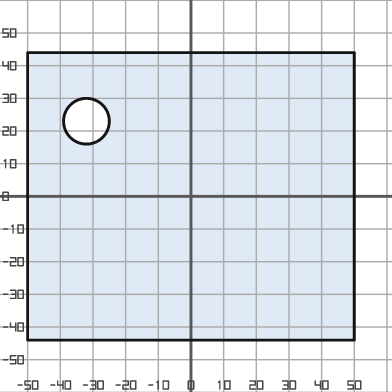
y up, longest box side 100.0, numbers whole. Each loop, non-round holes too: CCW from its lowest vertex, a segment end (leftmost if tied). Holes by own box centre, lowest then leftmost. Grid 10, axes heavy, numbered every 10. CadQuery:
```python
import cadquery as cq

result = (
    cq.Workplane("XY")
    .moveTo(-50.0, -44.0)
    .lineTo(50.0, -44.0)
    .lineTo(50.0, 44.0)
    .lineTo(-50.0, 44.0)
    .close()
    .moveTo(-32.0, 23.0)
    .circle(7.0)
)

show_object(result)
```